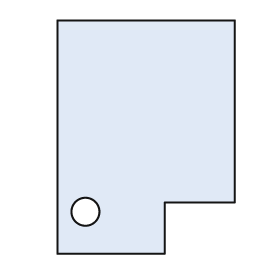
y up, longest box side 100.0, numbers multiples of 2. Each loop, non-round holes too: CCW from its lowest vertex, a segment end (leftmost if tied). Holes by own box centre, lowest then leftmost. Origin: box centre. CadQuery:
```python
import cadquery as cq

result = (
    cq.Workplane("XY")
    .moveTo(-38.0, -50.0)
    .lineTo(8.0, -50.0)
    .lineTo(8.0, -28.0)
    .lineTo(38.0, -28.0)
    .lineTo(38.0, 50.0)
    .lineTo(-38.0, 50.0)
    .close()
    .moveTo(-26.0, -32.0)
    .circle(6.0)
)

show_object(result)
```